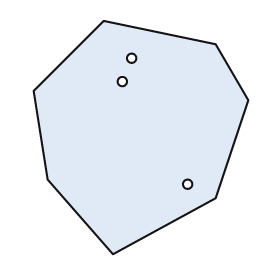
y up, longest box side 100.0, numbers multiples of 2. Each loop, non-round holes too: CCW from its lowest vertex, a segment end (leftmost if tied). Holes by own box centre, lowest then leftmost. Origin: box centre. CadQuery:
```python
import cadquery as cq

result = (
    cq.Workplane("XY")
    .moveTo(-12.0, -50.0)
    .lineTo(32.0, -26.0)
    .lineTo(46.0, 16.0)
    .lineTo(32.0, 40.0)
    .lineTo(-16.0, 50.0)
    .lineTo(-46.0, 20.0)
    .lineTo(-40.0, -18.0)
    .close()
    .moveTo(20.0, -20.0)
    .circle(2.0)
    .moveTo(-8.0, 24.0)
    .circle(2.0)
    .moveTo(-4.0, 34.0)
    .circle(2.0)
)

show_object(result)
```